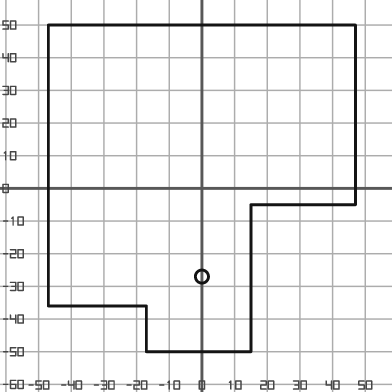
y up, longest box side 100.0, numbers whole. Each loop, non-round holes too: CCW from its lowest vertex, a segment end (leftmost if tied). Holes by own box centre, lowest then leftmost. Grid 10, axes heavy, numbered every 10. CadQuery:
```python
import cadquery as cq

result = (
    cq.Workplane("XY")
    .moveTo(-17.0, -50.0)
    .lineTo(15.0, -50.0)
    .lineTo(15.0, -5.0)
    .lineTo(47.0, -5.0)
    .lineTo(47.0, 50.0)
    .lineTo(-47.0, 50.0)
    .lineTo(-47.0, -36.0)
    .lineTo(-17.0, -36.0)
    .close()
    .moveTo(0.0, -27.0)
    .circle(2.0)
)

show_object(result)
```